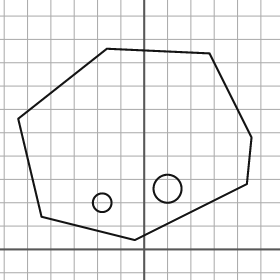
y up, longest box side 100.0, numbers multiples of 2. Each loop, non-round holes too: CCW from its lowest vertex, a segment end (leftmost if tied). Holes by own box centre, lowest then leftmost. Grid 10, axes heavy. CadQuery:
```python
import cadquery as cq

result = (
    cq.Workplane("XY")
    .moveTo(-4.0, 4.0)
    .lineTo(44.0, 28.0)
    .lineTo(46.0, 48.0)
    .lineTo(28.0, 84.0)
    .lineTo(-16.0, 86.0)
    .lineTo(-54.0, 56.0)
    .lineTo(-44.0, 14.0)
    .close()
    .moveTo(-18.0, 20.0)
    .circle(4.0)
    .moveTo(10.0, 26.0)
    .circle(6.0)
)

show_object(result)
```